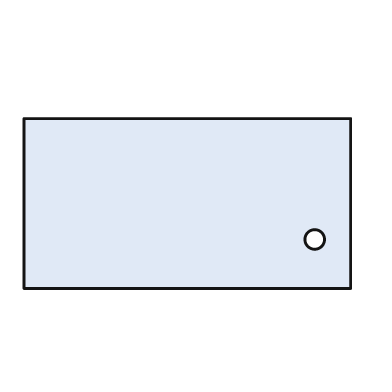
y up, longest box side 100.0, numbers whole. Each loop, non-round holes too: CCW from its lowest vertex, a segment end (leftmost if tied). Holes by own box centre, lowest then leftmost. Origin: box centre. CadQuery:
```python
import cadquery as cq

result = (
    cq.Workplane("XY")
    .moveTo(-50.0, -26.0)
    .lineTo(50.0, -26.0)
    .lineTo(50.0, 26.0)
    .lineTo(-50.0, 26.0)
    .close()
    .moveTo(39.0, -11.0)
    .circle(3.0)
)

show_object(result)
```